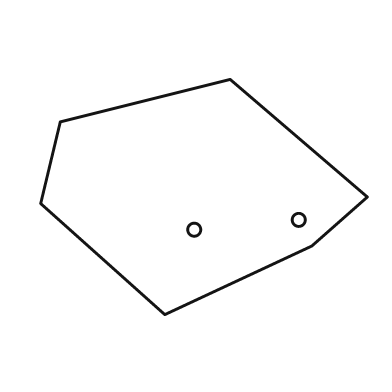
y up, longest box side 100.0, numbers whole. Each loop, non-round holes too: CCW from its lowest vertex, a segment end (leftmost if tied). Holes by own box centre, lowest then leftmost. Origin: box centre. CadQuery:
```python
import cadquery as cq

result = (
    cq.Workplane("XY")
    .moveTo(-12.0, -36.0)
    .lineTo(33.0, -15.0)
    .lineTo(50.0, 0.0)
    .lineTo(8.0, 36.0)
    .lineTo(-44.0, 23.0)
    .lineTo(-50.0, -2.0)
    .close()
    .moveTo(-3.0, -10.0)
    .circle(2.0)
    .moveTo(29.0, -7.0)
    .circle(2.0)
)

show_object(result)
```